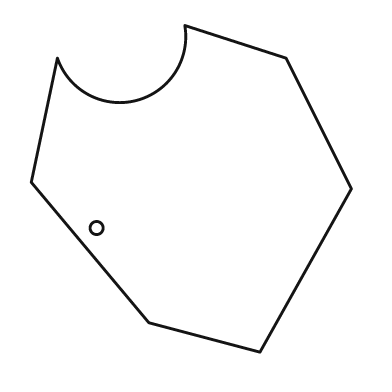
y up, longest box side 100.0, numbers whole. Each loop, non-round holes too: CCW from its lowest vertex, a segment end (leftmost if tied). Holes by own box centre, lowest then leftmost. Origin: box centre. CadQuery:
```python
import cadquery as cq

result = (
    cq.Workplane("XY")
    .moveTo(21.0, -50.0)
    .lineTo(49.0, 0.0)
    .lineTo(29.0, 40.0)
    .lineTo(-2.0, 50.0)
    .threePointArc((-17.0, 27.0), (-41.0, 40.0))
    .lineTo(-49.0, 2.0)
    .lineTo(-13.0, -41.0)
    .close()
    .moveTo(-29.0, -12.0)
    .circle(2.0)
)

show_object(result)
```